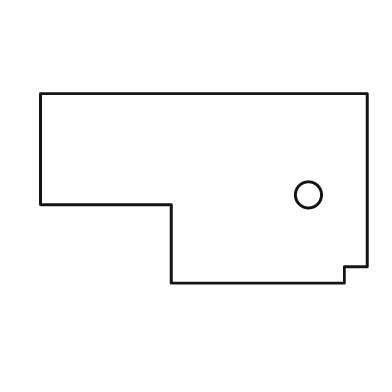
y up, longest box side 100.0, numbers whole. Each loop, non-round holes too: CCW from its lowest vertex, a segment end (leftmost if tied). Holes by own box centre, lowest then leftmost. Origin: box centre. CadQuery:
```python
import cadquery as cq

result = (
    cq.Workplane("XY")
    .moveTo(-10.0, -29.0)
    .lineTo(43.0, -29.0)
    .lineTo(43.0, -24.0)
    .lineTo(50.0, -24.0)
    .lineTo(50.0, 29.0)
    .lineTo(-50.0, 29.0)
    .lineTo(-50.0, -5.0)
    .lineTo(-10.0, -5.0)
    .close()
    .moveTo(32.0, -2.0)
    .circle(4.0)
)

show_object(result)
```